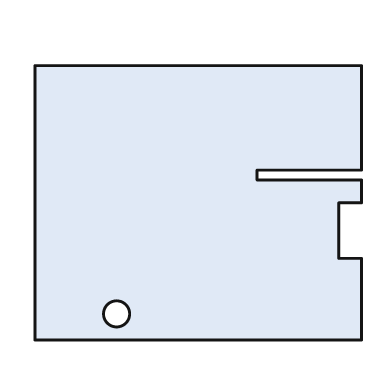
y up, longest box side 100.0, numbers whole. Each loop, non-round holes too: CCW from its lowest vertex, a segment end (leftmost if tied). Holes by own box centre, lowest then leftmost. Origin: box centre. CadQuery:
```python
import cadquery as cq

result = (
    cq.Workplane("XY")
    .moveTo(-50.0, -42.0)
    .lineTo(50.0, -42.0)
    .lineTo(50.0, -17.0)
    .lineTo(43.0, -17.0)
    .lineTo(43.0, 0.0)
    .lineTo(50.0, 0.0)
    .lineTo(50.0, 7.0)
    .lineTo(18.0, 7.0)
    .lineTo(18.0, 10.0)
    .lineTo(50.0, 10.0)
    .lineTo(50.0, 42.0)
    .lineTo(-50.0, 42.0)
    .close()
    .moveTo(-25.0, -34.0)
    .circle(4.0)
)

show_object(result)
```